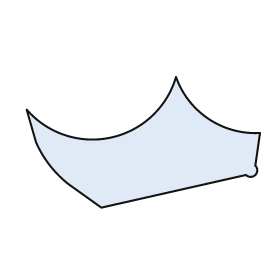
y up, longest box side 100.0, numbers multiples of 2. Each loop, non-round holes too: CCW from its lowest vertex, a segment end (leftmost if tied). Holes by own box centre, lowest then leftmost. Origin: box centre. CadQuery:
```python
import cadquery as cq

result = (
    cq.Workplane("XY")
    .moveTo(-18.0, -28.0)
    .lineTo(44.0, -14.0)
    .threePointArc((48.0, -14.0), (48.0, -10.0))
    .lineTo(50.0, 4.0)
    .threePointArc((28.0, 10.0), (14.0, 28.0))
    .threePointArc((-14.0, 2.0), (-50.0, 14.0))
    .lineTo(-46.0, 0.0)
    .threePointArc((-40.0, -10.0), (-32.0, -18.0))
    .close()
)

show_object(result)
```